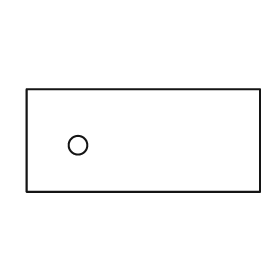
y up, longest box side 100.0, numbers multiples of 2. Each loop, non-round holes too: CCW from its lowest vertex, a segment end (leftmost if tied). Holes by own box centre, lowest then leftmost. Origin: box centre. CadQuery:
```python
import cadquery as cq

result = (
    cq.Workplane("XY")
    .moveTo(-50.0, -22.0)
    .lineTo(50.0, -22.0)
    .lineTo(50.0, 22.0)
    .lineTo(-50.0, 22.0)
    .close()
    .moveTo(-28.0, -2.0)
    .circle(4.0)
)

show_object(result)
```